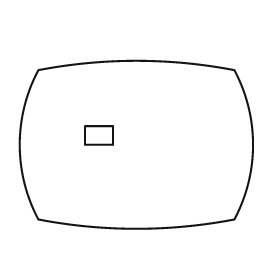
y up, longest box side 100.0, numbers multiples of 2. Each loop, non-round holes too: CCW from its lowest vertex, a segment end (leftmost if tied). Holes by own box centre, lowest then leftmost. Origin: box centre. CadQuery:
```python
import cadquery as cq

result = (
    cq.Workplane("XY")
    .moveTo(-42.0, -32.0)
    .threePointArc((0.0, -36.0), (42.0, -32.0))
    .threePointArc((50.0, 0.0), (42.0, 32.0))
    .threePointArc((0.0, 36.0), (-42.0, 32.0))
    .threePointArc((-50.0, 0.0), (-42.0, -32.0))
    .close()
    .moveTo(-22.0, 0.0)
    .lineTo(-10.0, 0.0)
    .lineTo(-10.0, 8.0)
    .lineTo(-22.0, 8.0)
    .close()
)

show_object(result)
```